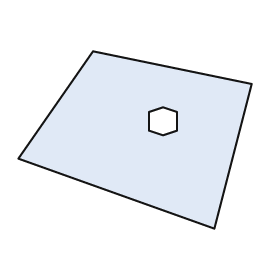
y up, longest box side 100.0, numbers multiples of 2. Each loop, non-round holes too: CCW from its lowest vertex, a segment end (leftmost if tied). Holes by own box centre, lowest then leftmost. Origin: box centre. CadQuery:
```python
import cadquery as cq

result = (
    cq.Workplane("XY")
    .moveTo(34.0, -38.0)
    .lineTo(50.0, 24.0)
    .lineTo(-18.0, 38.0)
    .lineTo(-50.0, -8.0)
    .close()
    .moveTo(12.0, 2.0)
    .lineTo(18.0, 4.0)
    .lineTo(18.0, 12.0)
    .lineTo(12.0, 14.0)
    .lineTo(6.0, 12.0)
    .lineTo(6.0, 4.0)
    .close()
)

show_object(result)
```